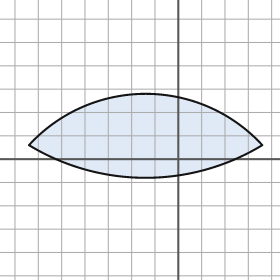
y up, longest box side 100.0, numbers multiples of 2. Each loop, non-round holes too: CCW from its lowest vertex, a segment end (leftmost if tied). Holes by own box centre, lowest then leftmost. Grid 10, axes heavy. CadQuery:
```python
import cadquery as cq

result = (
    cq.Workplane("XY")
    .moveTo(-64.0, 6.0)
    .threePointArc((-14.0, -8.0), (36.0, 6.0))
    .threePointArc((-14.0, 28.0), (-64.0, 6.0))
    .close()
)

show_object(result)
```